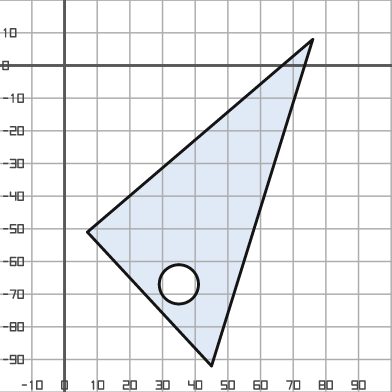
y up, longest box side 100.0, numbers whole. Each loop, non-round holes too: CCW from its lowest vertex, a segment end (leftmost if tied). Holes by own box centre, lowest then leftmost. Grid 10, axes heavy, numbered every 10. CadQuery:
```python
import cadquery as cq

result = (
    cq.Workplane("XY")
    .moveTo(45.0, -92.0)
    .lineTo(76.0, 8.0)
    .lineTo(7.0, -51.0)
    .close()
    .moveTo(35.0, -67.0)
    .circle(6.0)
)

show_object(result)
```